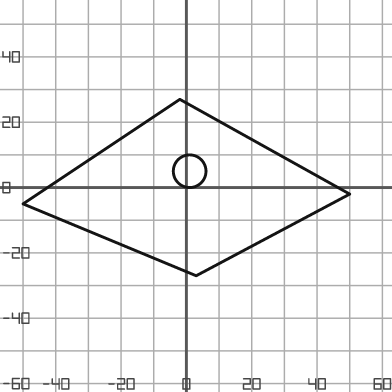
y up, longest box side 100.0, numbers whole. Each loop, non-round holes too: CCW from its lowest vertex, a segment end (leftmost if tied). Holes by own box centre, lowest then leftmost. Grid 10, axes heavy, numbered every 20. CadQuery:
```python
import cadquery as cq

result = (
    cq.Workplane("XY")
    .moveTo(3.0, -27.0)
    .lineTo(50.0, -2.0)
    .lineTo(-2.0, 27.0)
    .lineTo(-50.0, -5.0)
    .close()
    .moveTo(1.0, 5.0)
    .circle(5.0)
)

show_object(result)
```